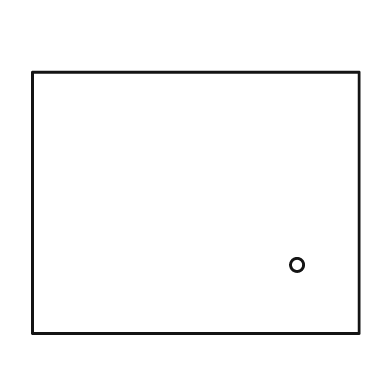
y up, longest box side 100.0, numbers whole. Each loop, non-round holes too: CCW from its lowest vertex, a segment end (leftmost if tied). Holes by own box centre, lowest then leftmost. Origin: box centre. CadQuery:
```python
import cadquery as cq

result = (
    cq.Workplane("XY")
    .moveTo(-50.0, -40.0)
    .lineTo(50.0, -40.0)
    .lineTo(50.0, 40.0)
    .lineTo(-50.0, 40.0)
    .close()
    .moveTo(31.0, -19.0)
    .circle(2.0)
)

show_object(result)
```